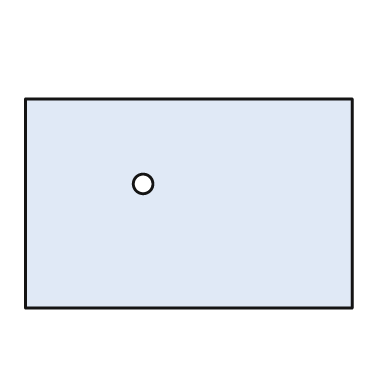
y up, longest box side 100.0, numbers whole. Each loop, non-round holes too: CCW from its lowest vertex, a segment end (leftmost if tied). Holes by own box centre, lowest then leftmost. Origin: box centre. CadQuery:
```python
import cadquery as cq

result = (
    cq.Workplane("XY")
    .moveTo(-50.0, -32.0)
    .lineTo(50.0, -32.0)
    .lineTo(50.0, 32.0)
    .lineTo(-50.0, 32.0)
    .close()
    .moveTo(-14.0, 6.0)
    .circle(3.0)
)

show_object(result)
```